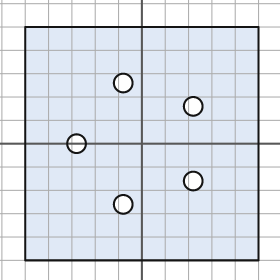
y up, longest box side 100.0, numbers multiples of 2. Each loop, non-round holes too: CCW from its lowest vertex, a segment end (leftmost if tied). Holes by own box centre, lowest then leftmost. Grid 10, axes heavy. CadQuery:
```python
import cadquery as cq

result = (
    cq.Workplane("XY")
    .moveTo(-50.0, -50.0)
    .lineTo(50.0, -50.0)
    .lineTo(50.0, 50.0)
    .lineTo(-50.0, 50.0)
    .close()
    .moveTo(-8.0, -26.0)
    .circle(4.0)
    .moveTo(22.0, -16.0)
    .circle(4.0)
    .moveTo(-28.0, 0.0)
    .circle(4.0)
    .moveTo(22.0, 16.0)
    .circle(4.0)
    .moveTo(-8.0, 26.0)
    .circle(4.0)
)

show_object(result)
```